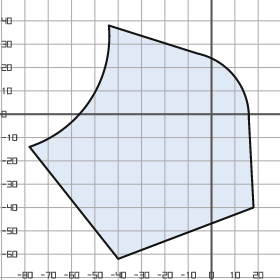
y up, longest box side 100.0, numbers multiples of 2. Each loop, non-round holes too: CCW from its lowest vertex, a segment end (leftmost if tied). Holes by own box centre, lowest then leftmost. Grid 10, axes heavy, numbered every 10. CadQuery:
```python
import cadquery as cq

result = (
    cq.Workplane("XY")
    .moveTo(-40.0, -62.0)
    .lineTo(18.0, -40.0)
    .lineTo(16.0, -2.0)
    .threePointArc((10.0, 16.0), (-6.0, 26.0))
    .lineTo(-44.0, 38.0)
    .threePointArc((-52.0, 6.0), (-78.0, -14.0))
    .close()
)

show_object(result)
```